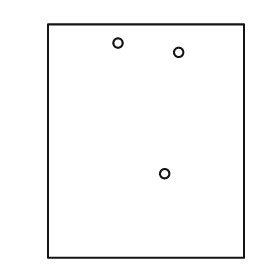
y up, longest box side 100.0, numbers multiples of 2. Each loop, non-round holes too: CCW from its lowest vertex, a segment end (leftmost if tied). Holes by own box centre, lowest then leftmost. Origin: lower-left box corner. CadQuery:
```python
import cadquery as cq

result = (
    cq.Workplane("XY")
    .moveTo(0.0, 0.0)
    .lineTo(84.0, 0.0)
    .lineTo(84.0, 100.0)
    .lineTo(0.0, 100.0)
    .close()
    .moveTo(50.0, 36.0)
    .circle(2.0)
    .moveTo(56.0, 88.0)
    .circle(2.0)
    .moveTo(30.0, 92.0)
    .circle(2.0)
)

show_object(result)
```